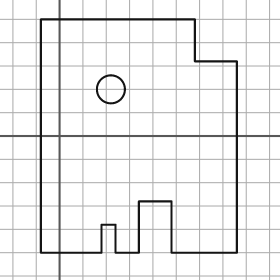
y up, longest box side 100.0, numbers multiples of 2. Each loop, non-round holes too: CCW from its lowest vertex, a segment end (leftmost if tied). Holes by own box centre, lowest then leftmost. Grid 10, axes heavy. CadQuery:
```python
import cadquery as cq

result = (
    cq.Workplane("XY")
    .moveTo(-8.0, -50.0)
    .lineTo(18.0, -50.0)
    .lineTo(18.0, -38.0)
    .lineTo(24.0, -38.0)
    .lineTo(24.0, -50.0)
    .lineTo(34.0, -50.0)
    .lineTo(34.0, -28.0)
    .lineTo(48.0, -28.0)
    .lineTo(48.0, -50.0)
    .lineTo(76.0, -50.0)
    .lineTo(76.0, 32.0)
    .lineTo(58.0, 32.0)
    .lineTo(58.0, 50.0)
    .lineTo(-8.0, 50.0)
    .close()
    .moveTo(22.0, 20.0)
    .circle(6.0)
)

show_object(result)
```